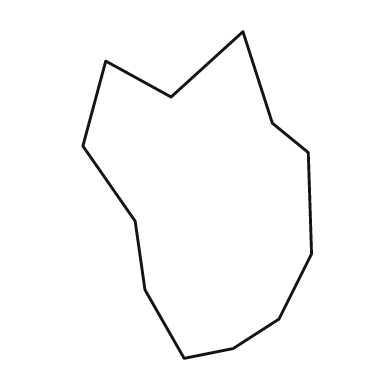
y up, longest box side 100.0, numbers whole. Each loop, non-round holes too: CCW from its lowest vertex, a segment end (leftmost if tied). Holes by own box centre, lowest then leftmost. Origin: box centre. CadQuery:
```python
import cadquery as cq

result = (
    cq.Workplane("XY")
    .moveTo(-4.0, -50.0)
    .lineTo(11.0, -47.0)
    .lineTo(25.0, -38.0)
    .lineTo(35.0, -18.0)
    .lineTo(34.0, 13.0)
    .lineTo(23.0, 22.0)
    .lineTo(14.0, 50.0)
    .lineTo(-8.0, 30.0)
    .lineTo(-28.0, 41.0)
    .lineTo(-35.0, 15.0)
    .lineTo(-19.0, -8.0)
    .lineTo(-16.0, -29.0)
    .close()
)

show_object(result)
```